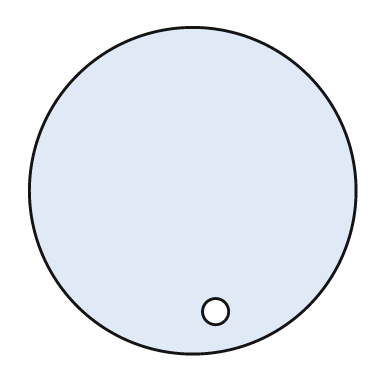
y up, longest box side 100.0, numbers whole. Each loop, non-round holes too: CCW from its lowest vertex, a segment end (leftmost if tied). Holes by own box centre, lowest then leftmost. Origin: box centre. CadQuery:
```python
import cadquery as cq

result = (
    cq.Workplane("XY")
    .moveTo(0.0, 0.0)
    .circle(50.0)
    .moveTo(7.0, -37.0)
    .circle(4.0)
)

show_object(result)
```